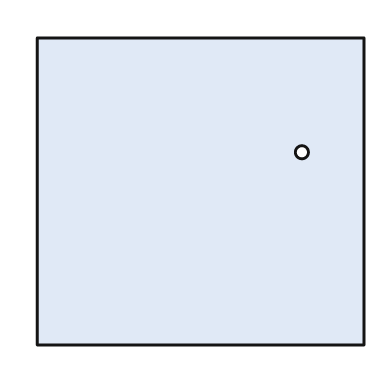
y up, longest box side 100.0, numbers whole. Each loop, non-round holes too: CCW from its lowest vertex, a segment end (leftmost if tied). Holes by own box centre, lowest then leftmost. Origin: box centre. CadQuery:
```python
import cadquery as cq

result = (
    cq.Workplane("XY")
    .moveTo(-50.0, -47.0)
    .lineTo(50.0, -47.0)
    .lineTo(50.0, 47.0)
    .lineTo(-50.0, 47.0)
    .close()
    .moveTo(31.0, 12.0)
    .circle(2.0)
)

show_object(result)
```